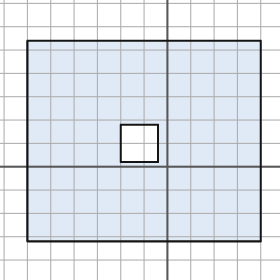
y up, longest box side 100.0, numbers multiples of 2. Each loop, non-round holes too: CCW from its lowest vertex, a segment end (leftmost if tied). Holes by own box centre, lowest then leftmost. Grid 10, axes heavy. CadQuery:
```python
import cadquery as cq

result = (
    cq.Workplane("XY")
    .moveTo(-60.0, -32.0)
    .lineTo(40.0, -32.0)
    .lineTo(40.0, 54.0)
    .lineTo(-60.0, 54.0)
    .close()
    .moveTo(-20.0, 2.0)
    .lineTo(-4.0, 2.0)
    .lineTo(-4.0, 18.0)
    .lineTo(-20.0, 18.0)
    .close()
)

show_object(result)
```